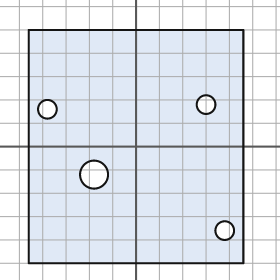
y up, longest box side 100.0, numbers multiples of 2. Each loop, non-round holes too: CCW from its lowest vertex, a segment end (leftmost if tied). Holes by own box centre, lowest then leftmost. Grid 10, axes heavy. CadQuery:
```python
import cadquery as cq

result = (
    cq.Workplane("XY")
    .moveTo(-46.0, -50.0)
    .lineTo(46.0, -50.0)
    .lineTo(46.0, 50.0)
    .lineTo(-46.0, 50.0)
    .close()
    .moveTo(38.0, -36.0)
    .circle(4.0)
    .moveTo(-18.0, -12.0)
    .circle(6.0)
    .moveTo(-38.0, 16.0)
    .circle(4.0)
    .moveTo(30.0, 18.0)
    .circle(4.0)
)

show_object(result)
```